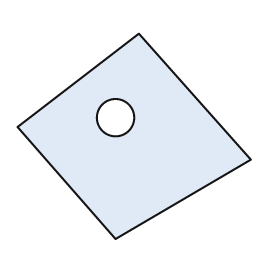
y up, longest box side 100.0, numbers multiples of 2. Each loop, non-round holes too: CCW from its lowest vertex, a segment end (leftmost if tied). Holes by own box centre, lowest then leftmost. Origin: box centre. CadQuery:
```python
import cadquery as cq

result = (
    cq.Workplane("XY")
    .moveTo(-8.0, -44.0)
    .lineTo(50.0, -10.0)
    .lineTo(2.0, 44.0)
    .lineTo(-50.0, 4.0)
    .close()
    .moveTo(-8.0, 8.0)
    .circle(8.0)
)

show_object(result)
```